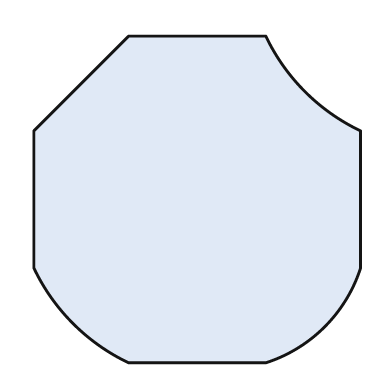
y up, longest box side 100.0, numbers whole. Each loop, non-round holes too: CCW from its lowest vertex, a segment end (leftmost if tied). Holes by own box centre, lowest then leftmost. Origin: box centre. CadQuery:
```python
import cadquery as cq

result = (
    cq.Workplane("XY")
    .moveTo(-21.0, -50.0)
    .lineTo(21.0, -50.0)
    .threePointArc((39.0, -39.0), (50.0, -21.0))
    .lineTo(50.0, 21.0)
    .threePointArc((33.0, 33.0), (21.0, 50.0))
    .lineTo(-21.0, 50.0)
    .lineTo(-50.0, 21.0)
    .lineTo(-50.0, -21.0)
    .threePointArc((-38.0, -38.0), (-21.0, -50.0))
    .close()
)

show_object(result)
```